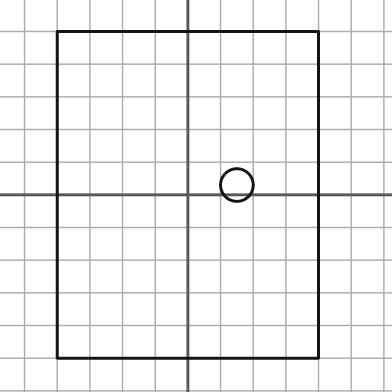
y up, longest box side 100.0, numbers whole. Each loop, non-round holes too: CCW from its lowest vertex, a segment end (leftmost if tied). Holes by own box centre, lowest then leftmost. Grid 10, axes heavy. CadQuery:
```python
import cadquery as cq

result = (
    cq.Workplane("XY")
    .moveTo(-40.0, -50.0)
    .lineTo(40.0, -50.0)
    .lineTo(40.0, 50.0)
    .lineTo(-40.0, 50.0)
    .close()
    .moveTo(15.0, 3.0)
    .circle(5.0)
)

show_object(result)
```